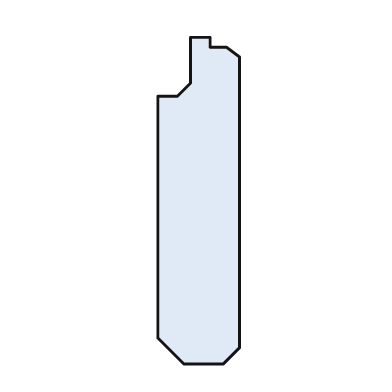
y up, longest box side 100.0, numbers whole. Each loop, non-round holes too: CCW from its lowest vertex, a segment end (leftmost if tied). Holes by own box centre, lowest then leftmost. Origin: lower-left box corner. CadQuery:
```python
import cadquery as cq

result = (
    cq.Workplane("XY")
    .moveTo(8.0, 0.0)
    .lineTo(20.0, 0.0)
    .lineTo(25.0, 5.0)
    .lineTo(25.0, 94.0)
    .lineTo(21.0, 97.0)
    .lineTo(16.0, 97.0)
    .lineTo(16.0, 100.0)
    .lineTo(10.0, 100.0)
    .lineTo(10.0, 86.0)
    .lineTo(6.0, 82.0)
    .lineTo(0.0, 82.0)
    .lineTo(0.0, 8.0)
    .close()
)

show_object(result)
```